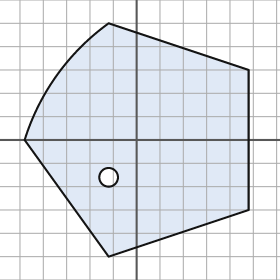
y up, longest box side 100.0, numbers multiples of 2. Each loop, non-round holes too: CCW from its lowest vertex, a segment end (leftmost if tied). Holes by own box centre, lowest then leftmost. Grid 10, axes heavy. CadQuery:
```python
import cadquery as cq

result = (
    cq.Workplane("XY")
    .moveTo(-12.0, -50.0)
    .lineTo(48.0, -30.0)
    .lineTo(48.0, 30.0)
    .lineTo(-12.0, 50.0)
    .threePointArc((-34.0, 28.0), (-48.0, 0.0))
    .close()
    .moveTo(-12.0, -16.0)
    .circle(4.0)
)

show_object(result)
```